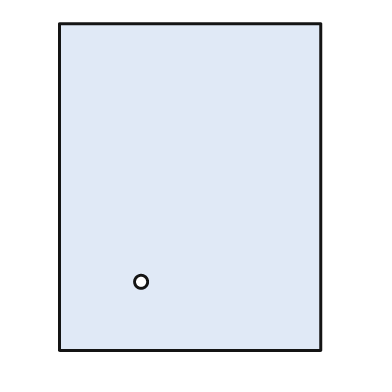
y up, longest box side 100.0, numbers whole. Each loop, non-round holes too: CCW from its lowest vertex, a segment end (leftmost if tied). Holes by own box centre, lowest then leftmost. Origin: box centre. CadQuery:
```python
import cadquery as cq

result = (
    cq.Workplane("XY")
    .moveTo(-40.0, -50.0)
    .lineTo(40.0, -50.0)
    .lineTo(40.0, 50.0)
    .lineTo(-40.0, 50.0)
    .close()
    .moveTo(-15.0, -29.0)
    .circle(2.0)
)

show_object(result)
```